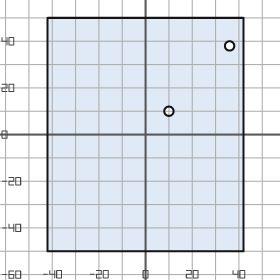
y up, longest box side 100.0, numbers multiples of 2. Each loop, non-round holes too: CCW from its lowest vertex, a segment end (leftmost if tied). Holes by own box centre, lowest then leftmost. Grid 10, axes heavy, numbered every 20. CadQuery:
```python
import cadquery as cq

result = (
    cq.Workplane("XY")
    .moveTo(-42.0, -50.0)
    .lineTo(42.0, -50.0)
    .lineTo(42.0, 50.0)
    .lineTo(-42.0, 50.0)
    .close()
    .moveTo(10.0, 10.0)
    .circle(2.0)
    .moveTo(36.0, 38.0)
    .circle(2.0)
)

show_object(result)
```